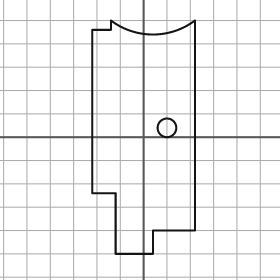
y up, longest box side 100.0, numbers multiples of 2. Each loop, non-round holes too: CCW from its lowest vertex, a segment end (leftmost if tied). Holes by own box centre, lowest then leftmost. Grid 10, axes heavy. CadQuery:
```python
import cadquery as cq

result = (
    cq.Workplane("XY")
    .moveTo(-12.0, -50.0)
    .lineTo(4.0, -50.0)
    .lineTo(4.0, -40.0)
    .lineTo(22.0, -40.0)
    .lineTo(22.0, 50.0)
    .threePointArc((4.0, 44.0), (-14.0, 50.0))
    .lineTo(-14.0, 46.0)
    .lineTo(-22.0, 46.0)
    .lineTo(-22.0, -24.0)
    .lineTo(-12.0, -24.0)
    .close()
    .moveTo(10.0, 4.0)
    .circle(4.0)
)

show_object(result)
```